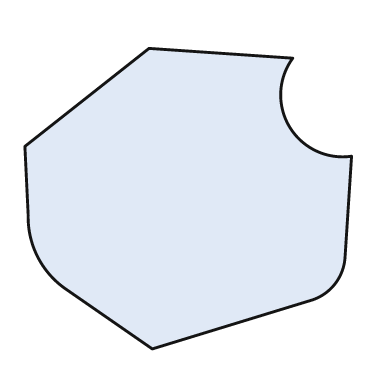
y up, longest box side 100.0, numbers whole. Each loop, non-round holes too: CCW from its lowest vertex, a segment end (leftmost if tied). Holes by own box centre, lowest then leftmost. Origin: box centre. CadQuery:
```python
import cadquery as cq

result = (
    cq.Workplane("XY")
    .moveTo(-11.0, -46.0)
    .lineTo(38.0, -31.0)
    .threePointArc((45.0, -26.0), (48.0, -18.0))
    .lineTo(50.0, 13.0)
    .threePointArc((31.0, 22.0), (32.0, 43.0))
    .lineTo(-12.0, 46.0)
    .lineTo(-50.0, 16.0)
    .lineTo(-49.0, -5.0)
    .threePointArc((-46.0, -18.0), (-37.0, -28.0))
    .close()
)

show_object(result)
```